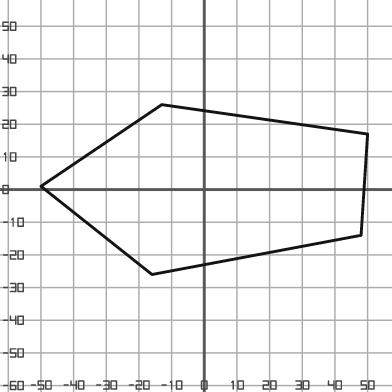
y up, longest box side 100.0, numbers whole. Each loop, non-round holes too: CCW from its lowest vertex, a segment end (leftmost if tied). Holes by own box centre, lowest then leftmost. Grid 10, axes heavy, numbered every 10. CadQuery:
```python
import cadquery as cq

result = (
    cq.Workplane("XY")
    .moveTo(-16.0, -26.0)
    .lineTo(48.0, -14.0)
    .lineTo(50.0, 17.0)
    .lineTo(-13.0, 26.0)
    .lineTo(-50.0, 1.0)
    .close()
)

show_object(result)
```